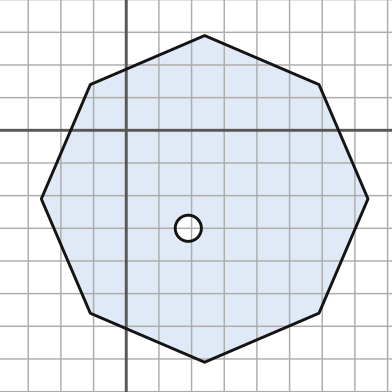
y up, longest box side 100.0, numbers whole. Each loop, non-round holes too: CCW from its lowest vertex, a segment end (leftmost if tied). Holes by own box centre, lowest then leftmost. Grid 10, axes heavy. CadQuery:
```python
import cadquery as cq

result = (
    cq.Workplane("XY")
    .moveTo(24.0, -71.0)
    .lineTo(59.0, -56.0)
    .lineTo(74.0, -21.0)
    .lineTo(59.0, 14.0)
    .lineTo(24.0, 29.0)
    .lineTo(-11.0, 14.0)
    .lineTo(-26.0, -21.0)
    .lineTo(-11.0, -56.0)
    .close()
    .moveTo(19.0, -30.0)
    .circle(4.0)
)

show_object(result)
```